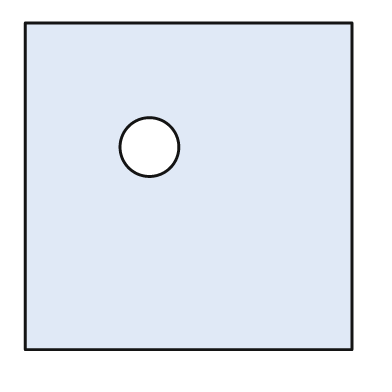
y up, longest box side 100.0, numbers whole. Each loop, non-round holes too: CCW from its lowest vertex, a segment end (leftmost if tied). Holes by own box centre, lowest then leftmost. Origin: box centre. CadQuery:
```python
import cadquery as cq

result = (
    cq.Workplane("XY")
    .moveTo(-50.0, -50.0)
    .lineTo(50.0, -50.0)
    .lineTo(50.0, 50.0)
    .lineTo(-50.0, 50.0)
    .close()
    .moveTo(-12.0, 12.0)
    .circle(9.0)
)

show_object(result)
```